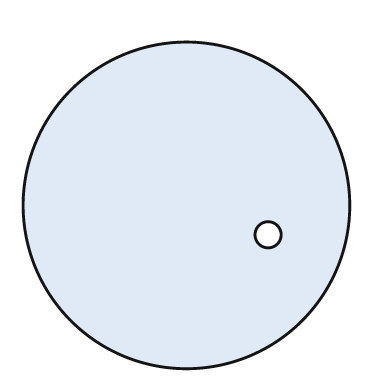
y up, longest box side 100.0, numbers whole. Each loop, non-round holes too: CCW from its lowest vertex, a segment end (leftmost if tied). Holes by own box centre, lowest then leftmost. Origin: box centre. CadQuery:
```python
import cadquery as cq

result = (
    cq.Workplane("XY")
    .moveTo(0.0, 0.0)
    .circle(50.0)
    .moveTo(25.0, -9.0)
    .circle(4.0)
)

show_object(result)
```